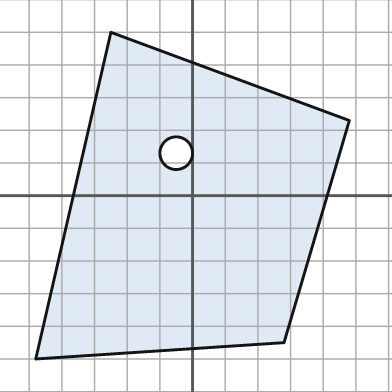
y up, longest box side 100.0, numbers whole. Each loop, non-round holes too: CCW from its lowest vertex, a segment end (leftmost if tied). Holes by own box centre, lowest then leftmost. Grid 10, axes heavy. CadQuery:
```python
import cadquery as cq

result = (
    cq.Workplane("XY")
    .moveTo(-48.0, -50.0)
    .lineTo(28.0, -45.0)
    .lineTo(48.0, 23.0)
    .lineTo(-25.0, 50.0)
    .close()
    .moveTo(-5.0, 13.0)
    .circle(5.0)
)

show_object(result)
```